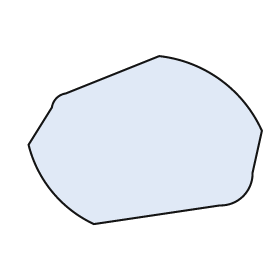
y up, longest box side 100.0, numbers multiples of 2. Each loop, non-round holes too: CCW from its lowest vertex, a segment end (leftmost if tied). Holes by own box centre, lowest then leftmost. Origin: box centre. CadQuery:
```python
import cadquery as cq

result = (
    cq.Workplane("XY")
    .moveTo(-22.0, -36.0)
    .lineTo(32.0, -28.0)
    .threePointArc((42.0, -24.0), (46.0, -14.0))
    .lineTo(50.0, 4.0)
    .threePointArc((32.0, 26.0), (6.0, 36.0))
    .lineTo(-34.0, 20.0)
    .threePointArc((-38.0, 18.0), (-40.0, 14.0))
    .lineTo(-50.0, -2.0)
    .threePointArc((-40.0, -22.0), (-22.0, -36.0))
    .close()
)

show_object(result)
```